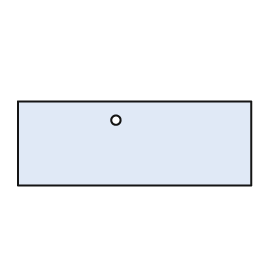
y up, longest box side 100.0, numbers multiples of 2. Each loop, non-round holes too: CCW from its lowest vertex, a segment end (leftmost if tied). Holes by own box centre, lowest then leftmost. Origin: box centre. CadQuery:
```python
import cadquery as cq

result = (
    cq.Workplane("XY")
    .moveTo(-50.0, -18.0)
    .lineTo(50.0, -18.0)
    .lineTo(50.0, 18.0)
    .lineTo(-50.0, 18.0)
    .close()
    .moveTo(-8.0, 10.0)
    .circle(2.0)
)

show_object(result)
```